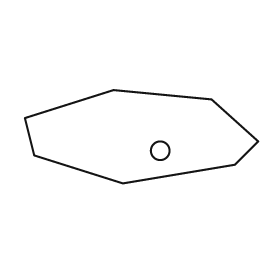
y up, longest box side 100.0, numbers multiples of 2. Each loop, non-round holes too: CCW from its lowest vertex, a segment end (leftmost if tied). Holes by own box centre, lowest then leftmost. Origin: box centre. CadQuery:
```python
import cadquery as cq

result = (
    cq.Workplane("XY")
    .moveTo(-8.0, -20.0)
    .lineTo(40.0, -12.0)
    .lineTo(50.0, -2.0)
    .lineTo(30.0, 16.0)
    .lineTo(-12.0, 20.0)
    .lineTo(-50.0, 8.0)
    .lineTo(-46.0, -8.0)
    .close()
    .moveTo(8.0, -6.0)
    .circle(4.0)
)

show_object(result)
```